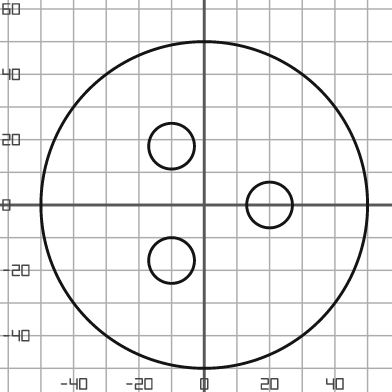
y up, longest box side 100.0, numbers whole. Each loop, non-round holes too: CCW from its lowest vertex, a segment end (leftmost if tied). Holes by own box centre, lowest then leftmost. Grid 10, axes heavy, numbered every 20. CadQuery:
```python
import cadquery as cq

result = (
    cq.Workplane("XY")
    .moveTo(0.0, 0.0)
    .circle(50.0)
    .moveTo(-10.0, -17.0)
    .circle(7.0)
    .moveTo(20.0, 0.0)
    .circle(7.0)
    .moveTo(-10.0, 18.0)
    .circle(7.0)
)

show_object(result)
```